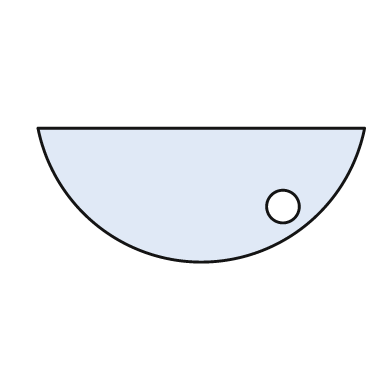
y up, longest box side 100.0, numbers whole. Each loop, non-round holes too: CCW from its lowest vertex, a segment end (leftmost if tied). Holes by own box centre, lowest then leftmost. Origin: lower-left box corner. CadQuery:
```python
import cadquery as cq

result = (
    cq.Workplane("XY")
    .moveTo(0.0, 41.0)
    .threePointArc((50.0, 0.0), (100.0, 41.0))
    .close()
    .moveTo(75.0, 17.0)
    .circle(5.0)
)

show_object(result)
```